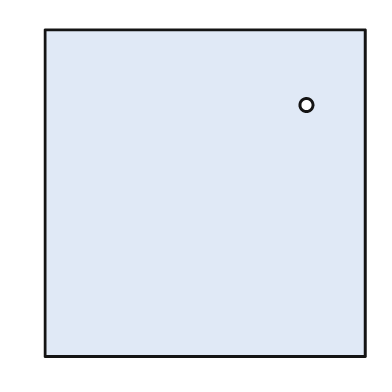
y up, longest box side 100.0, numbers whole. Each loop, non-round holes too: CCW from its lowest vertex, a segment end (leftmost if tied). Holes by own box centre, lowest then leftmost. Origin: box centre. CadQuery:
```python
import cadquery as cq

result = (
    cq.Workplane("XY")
    .moveTo(-49.0, -50.0)
    .lineTo(49.0, -50.0)
    .lineTo(49.0, 50.0)
    .lineTo(-49.0, 50.0)
    .close()
    .moveTo(31.0, 27.0)
    .circle(2.0)
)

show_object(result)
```